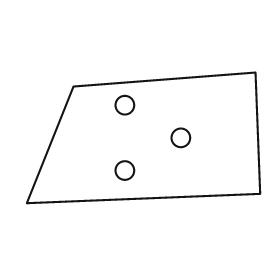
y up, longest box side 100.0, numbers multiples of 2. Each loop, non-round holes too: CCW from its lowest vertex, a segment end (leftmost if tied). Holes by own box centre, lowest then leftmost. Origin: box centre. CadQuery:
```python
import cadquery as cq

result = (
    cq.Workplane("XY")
    .moveTo(-50.0, -28.0)
    .lineTo(50.0, -24.0)
    .lineTo(48.0, 28.0)
    .lineTo(-30.0, 22.0)
    .close()
    .moveTo(-8.0, -14.0)
    .circle(4.0)
    .moveTo(16.0, 0.0)
    .circle(4.0)
    .moveTo(-8.0, 14.0)
    .circle(4.0)
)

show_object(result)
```